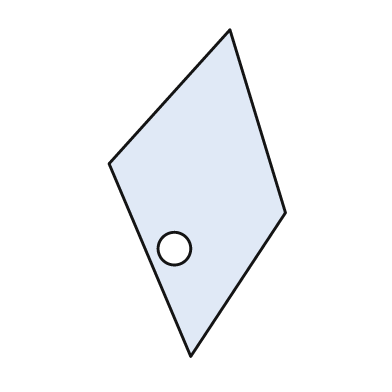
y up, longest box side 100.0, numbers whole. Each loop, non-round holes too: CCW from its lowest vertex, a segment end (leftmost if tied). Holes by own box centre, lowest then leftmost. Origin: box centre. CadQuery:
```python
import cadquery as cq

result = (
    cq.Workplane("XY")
    .moveTo(-2.0, -50.0)
    .lineTo(27.0, -6.0)
    .lineTo(10.0, 50.0)
    .lineTo(-27.0, 9.0)
    .close()
    .moveTo(-7.0, -17.0)
    .circle(5.0)
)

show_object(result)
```